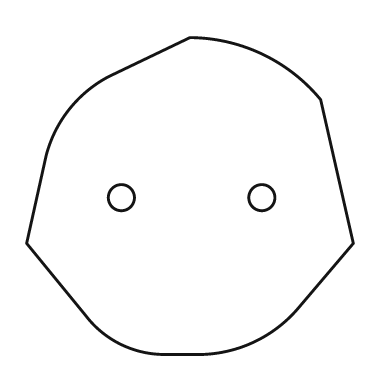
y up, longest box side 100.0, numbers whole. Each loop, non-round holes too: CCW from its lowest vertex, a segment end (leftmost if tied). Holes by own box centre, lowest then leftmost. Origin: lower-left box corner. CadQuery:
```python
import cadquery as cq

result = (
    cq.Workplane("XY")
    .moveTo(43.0, 0.0)
    .lineTo(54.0, 0.0)
    .threePointArc((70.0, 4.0), (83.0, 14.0))
    .lineTo(100.0, 34.0)
    .lineTo(90.0, 78.0)
    .threePointArc((72.0, 92.0), (50.0, 97.0))
    .lineTo(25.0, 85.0)
    .threePointArc((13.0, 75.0), (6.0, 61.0))
    .lineTo(0.0, 34.0)
    .lineTo(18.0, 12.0)
    .threePointArc((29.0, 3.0), (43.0, 0.0))
    .close()
    .moveTo(29.0, 48.0)
    .circle(4.0)
    .moveTo(72.0, 48.0)
    .circle(4.0)
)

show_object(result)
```